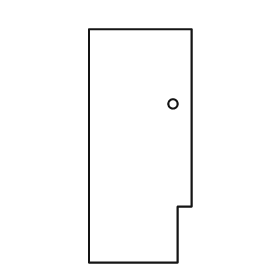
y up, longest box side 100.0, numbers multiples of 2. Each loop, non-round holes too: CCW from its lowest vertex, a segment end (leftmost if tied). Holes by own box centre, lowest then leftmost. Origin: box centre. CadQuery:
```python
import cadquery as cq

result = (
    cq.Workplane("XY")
    .moveTo(-22.0, -50.0)
    .lineTo(16.0, -50.0)
    .lineTo(16.0, -26.0)
    .lineTo(22.0, -26.0)
    .lineTo(22.0, 50.0)
    .lineTo(-22.0, 50.0)
    .close()
    .moveTo(14.0, 18.0)
    .circle(2.0)
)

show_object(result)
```